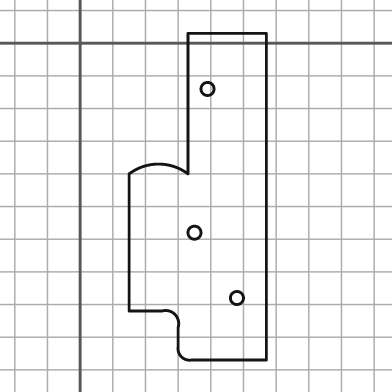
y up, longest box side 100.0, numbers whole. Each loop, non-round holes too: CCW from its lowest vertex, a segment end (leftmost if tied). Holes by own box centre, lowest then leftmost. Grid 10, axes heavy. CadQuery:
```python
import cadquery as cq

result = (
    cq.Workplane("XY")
    .moveTo(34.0, -97.0)
    .lineTo(57.0, -97.0)
    .lineTo(57.0, 3.0)
    .lineTo(33.0, 3.0)
    .lineTo(33.0, -40.0)
    .threePointArc((24.0, -37.0), (15.0, -40.0))
    .lineTo(15.0, -82.0)
    .lineTo(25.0, -82.0)
    .threePointArc((29.0, -83.0), (30.0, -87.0))
    .lineTo(30.0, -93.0)
    .threePointArc((31.0, -96.0), (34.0, -97.0))
    .close()
    .moveTo(48.0, -78.0)
    .circle(2.0)
    .moveTo(35.0, -58.0)
    .circle(2.0)
    .moveTo(39.0, -14.0)
    .circle(2.0)
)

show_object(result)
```